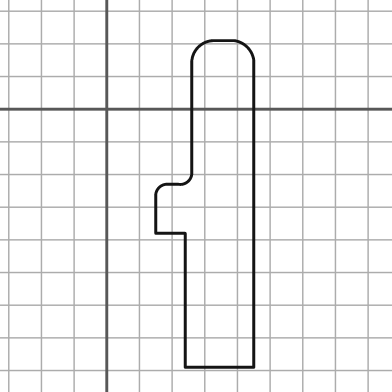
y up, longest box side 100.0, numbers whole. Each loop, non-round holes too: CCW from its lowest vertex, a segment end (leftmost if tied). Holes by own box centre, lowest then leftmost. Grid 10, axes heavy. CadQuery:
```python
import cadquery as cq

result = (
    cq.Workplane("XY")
    .moveTo(24.0, -79.0)
    .lineTo(45.0, -79.0)
    .lineTo(45.0, 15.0)
    .threePointArc((43.0, 19.0), (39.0, 21.0))
    .lineTo(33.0, 21.0)
    .threePointArc((28.0, 19.0), (26.0, 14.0))
    .lineTo(26.0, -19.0)
    .threePointArc((25.0, -22.0), (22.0, -23.0))
    .lineTo(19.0, -23.0)
    .threePointArc((16.0, -24.0), (15.0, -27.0))
    .lineTo(15.0, -38.0)
    .lineTo(24.0, -38.0)
    .close()
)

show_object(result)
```